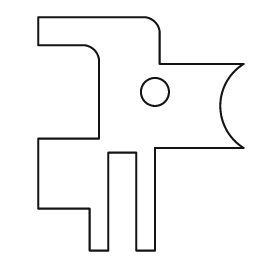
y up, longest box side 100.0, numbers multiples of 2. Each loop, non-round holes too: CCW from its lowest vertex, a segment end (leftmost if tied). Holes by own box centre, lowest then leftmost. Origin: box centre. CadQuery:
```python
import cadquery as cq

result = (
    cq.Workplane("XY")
    .moveTo(-22.0, -50.0)
    .lineTo(-14.0, -50.0)
    .lineTo(-14.0, -8.0)
    .lineTo(-2.0, -8.0)
    .lineTo(-2.0, -50.0)
    .lineTo(6.0, -50.0)
    .lineTo(6.0, -6.0)
    .lineTo(44.0, -6.0)
    .threePointArc((34.0, 12.0), (44.0, 30.0))
    .lineTo(8.0, 30.0)
    .lineTo(8.0, 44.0)
    .threePointArc((6.0, 48.0), (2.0, 50.0))
    .lineTo(-44.0, 50.0)
    .lineTo(-44.0, 38.0)
    .lineTo(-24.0, 38.0)
    .threePointArc((-20.0, 36.0), (-18.0, 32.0))
    .lineTo(-18.0, -2.0)
    .lineTo(-44.0, -2.0)
    .lineTo(-44.0, -32.0)
    .lineTo(-22.0, -32.0)
    .close()
    .moveTo(6.0, 18.0)
    .circle(6.0)
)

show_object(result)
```